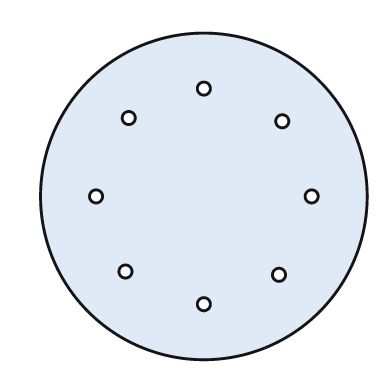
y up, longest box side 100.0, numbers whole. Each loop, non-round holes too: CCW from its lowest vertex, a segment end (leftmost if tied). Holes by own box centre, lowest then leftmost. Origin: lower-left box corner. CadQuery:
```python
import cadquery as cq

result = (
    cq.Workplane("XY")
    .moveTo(50.0, 50.0)
    .circle(50.0)
    .moveTo(50.0, 17.0)
    .circle(2.0)
    .moveTo(73.0, 26.0)
    .circle(2.0)
    .moveTo(26.0, 27.0)
    .circle(2.0)
    .moveTo(17.0, 50.0)
    .circle(2.0)
    .moveTo(83.0, 50.0)
    .circle(2.0)
    .moveTo(74.0, 73.0)
    .circle(2.0)
    .moveTo(27.0, 74.0)
    .circle(2.0)
    .moveTo(50.0, 83.0)
    .circle(2.0)
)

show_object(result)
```